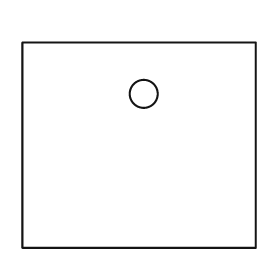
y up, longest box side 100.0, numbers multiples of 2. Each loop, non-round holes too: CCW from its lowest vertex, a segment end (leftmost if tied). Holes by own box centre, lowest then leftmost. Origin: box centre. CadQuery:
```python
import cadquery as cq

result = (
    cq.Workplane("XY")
    .moveTo(-50.0, -44.0)
    .lineTo(50.0, -44.0)
    .lineTo(50.0, 44.0)
    .lineTo(-50.0, 44.0)
    .close()
    .moveTo(2.0, 22.0)
    .circle(6.0)
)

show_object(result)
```